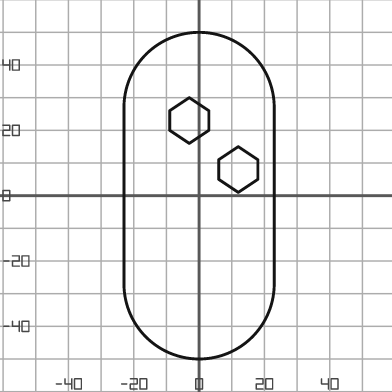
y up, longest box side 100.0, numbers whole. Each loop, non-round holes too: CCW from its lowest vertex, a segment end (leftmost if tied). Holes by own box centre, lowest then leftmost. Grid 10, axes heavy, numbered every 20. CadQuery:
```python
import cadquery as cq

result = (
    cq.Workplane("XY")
    .moveTo(-23.0, -27.0)
    .threePointArc((0.0, -50.0), (23.0, -27.0))
    .lineTo(23.0, 27.0)
    .threePointArc((0.0, 50.0), (-23.0, 27.0))
    .close()
    .moveTo(12.0, 1.0)
    .lineTo(18.0, 5.0)
    .lineTo(18.0, 11.0)
    .lineTo(12.0, 15.0)
    .lineTo(6.0, 11.0)
    .lineTo(6.0, 5.0)
    .close()
    .moveTo(-3.0, 16.0)
    .lineTo(3.0, 20.0)
    .lineTo(3.0, 26.0)
    .lineTo(-3.0, 30.0)
    .lineTo(-9.0, 26.0)
    .lineTo(-9.0, 20.0)
    .close()
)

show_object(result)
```